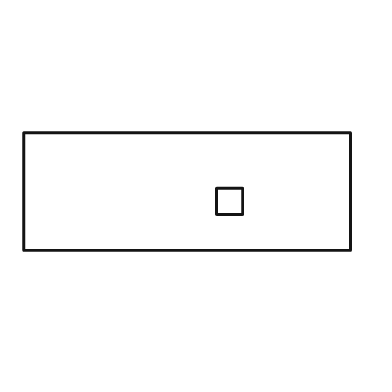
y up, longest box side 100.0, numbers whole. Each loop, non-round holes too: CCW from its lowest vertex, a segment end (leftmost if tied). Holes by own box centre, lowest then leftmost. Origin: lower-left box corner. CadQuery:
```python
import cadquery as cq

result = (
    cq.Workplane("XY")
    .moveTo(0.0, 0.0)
    .lineTo(100.0, 0.0)
    .lineTo(100.0, 36.0)
    .lineTo(0.0, 36.0)
    .close()
    .moveTo(59.0, 11.0)
    .lineTo(67.0, 11.0)
    .lineTo(67.0, 19.0)
    .lineTo(59.0, 19.0)
    .close()
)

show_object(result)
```